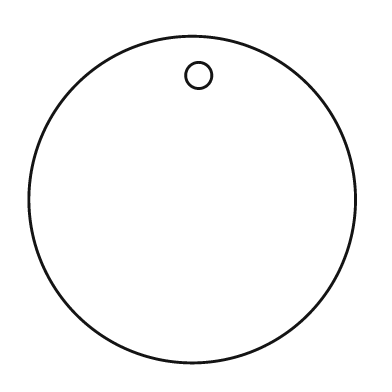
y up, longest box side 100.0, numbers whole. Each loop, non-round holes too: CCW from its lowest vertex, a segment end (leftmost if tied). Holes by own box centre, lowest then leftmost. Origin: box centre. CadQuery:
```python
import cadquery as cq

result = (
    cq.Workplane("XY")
    .moveTo(0.0, 0.0)
    .circle(50.0)
    .moveTo(2.0, 38.0)
    .circle(4.0)
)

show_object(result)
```